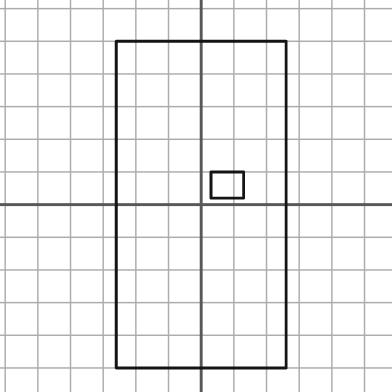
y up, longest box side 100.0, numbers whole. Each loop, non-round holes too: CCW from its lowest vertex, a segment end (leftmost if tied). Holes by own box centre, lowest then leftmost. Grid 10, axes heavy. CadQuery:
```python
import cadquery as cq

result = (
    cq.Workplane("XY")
    .moveTo(-26.0, -50.0)
    .lineTo(26.0, -50.0)
    .lineTo(26.0, 50.0)
    .lineTo(-26.0, 50.0)
    .close()
    .moveTo(3.0, 2.0)
    .lineTo(13.0, 2.0)
    .lineTo(13.0, 10.0)
    .lineTo(3.0, 10.0)
    .close()
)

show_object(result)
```